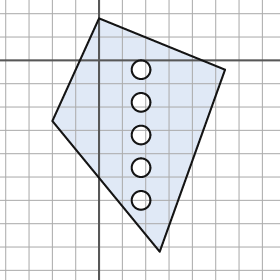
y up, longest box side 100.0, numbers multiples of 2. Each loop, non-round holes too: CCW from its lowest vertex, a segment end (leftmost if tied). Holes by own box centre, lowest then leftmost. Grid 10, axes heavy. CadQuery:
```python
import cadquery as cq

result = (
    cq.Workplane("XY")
    .moveTo(26.0, -82.0)
    .lineTo(54.0, -4.0)
    .lineTo(0.0, 18.0)
    .lineTo(-20.0, -26.0)
    .close()
    .moveTo(18.0, -60.0)
    .circle(4.0)
    .moveTo(18.0, -46.0)
    .circle(4.0)
    .moveTo(18.0, -32.0)
    .circle(4.0)
    .moveTo(18.0, -18.0)
    .circle(4.0)
    .moveTo(18.0, -4.0)
    .circle(4.0)
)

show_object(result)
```